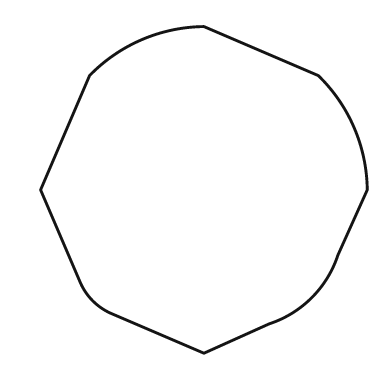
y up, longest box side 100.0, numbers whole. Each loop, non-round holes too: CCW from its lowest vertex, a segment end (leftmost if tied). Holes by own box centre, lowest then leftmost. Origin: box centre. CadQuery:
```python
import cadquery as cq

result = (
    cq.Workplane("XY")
    .moveTo(0.0, -50.0)
    .lineTo(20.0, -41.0)
    .threePointArc((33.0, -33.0), (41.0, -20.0))
    .lineTo(50.0, 0.0)
    .threePointArc((46.0, 19.0), (35.0, 35.0))
    .lineTo(0.0, 50.0)
    .threePointArc((-19.0, 46.0), (-35.0, 35.0))
    .lineTo(-50.0, 0.0)
    .lineTo(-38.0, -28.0)
    .threePointArc((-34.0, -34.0), (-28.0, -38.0))
    .close()
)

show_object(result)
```